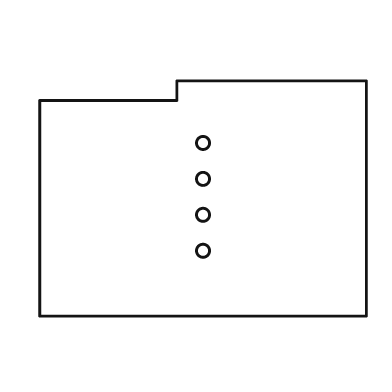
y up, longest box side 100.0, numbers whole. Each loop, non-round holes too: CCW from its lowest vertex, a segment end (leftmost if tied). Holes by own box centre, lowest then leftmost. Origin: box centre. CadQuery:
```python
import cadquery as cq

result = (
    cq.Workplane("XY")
    .moveTo(-50.0, -36.0)
    .lineTo(50.0, -36.0)
    .lineTo(50.0, 36.0)
    .lineTo(-8.0, 36.0)
    .lineTo(-8.0, 30.0)
    .lineTo(-50.0, 30.0)
    .close()
    .moveTo(0.0, -16.0)
    .circle(2.0)
    .moveTo(0.0, -5.0)
    .circle(2.0)
    .moveTo(0.0, 6.0)
    .circle(2.0)
    .moveTo(0.0, 17.0)
    .circle(2.0)
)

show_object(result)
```